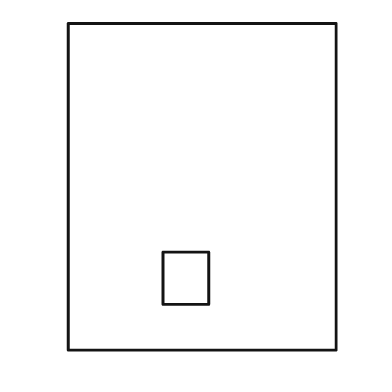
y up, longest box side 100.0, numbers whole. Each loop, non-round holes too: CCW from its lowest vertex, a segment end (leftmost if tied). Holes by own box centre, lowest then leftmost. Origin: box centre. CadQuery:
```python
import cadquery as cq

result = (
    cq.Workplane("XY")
    .moveTo(-41.0, -50.0)
    .lineTo(41.0, -50.0)
    .lineTo(41.0, 50.0)
    .lineTo(-41.0, 50.0)
    .close()
    .moveTo(-12.0, -36.0)
    .lineTo(2.0, -36.0)
    .lineTo(2.0, -20.0)
    .lineTo(-12.0, -20.0)
    .close()
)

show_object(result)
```